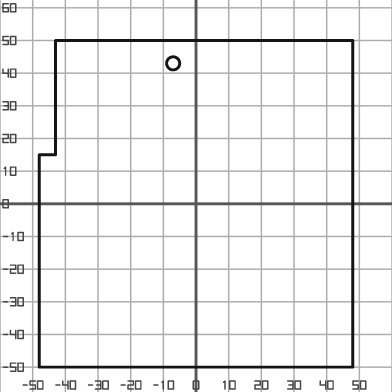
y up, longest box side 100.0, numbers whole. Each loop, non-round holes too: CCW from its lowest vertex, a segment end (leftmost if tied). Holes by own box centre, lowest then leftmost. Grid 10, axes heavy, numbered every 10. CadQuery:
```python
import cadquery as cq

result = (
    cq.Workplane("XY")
    .moveTo(-48.0, -50.0)
    .lineTo(48.0, -50.0)
    .lineTo(48.0, 50.0)
    .lineTo(-43.0, 50.0)
    .lineTo(-43.0, 15.0)
    .lineTo(-48.0, 15.0)
    .close()
    .moveTo(-7.0, 43.0)
    .circle(2.0)
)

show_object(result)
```